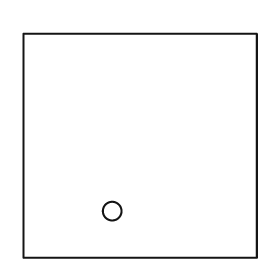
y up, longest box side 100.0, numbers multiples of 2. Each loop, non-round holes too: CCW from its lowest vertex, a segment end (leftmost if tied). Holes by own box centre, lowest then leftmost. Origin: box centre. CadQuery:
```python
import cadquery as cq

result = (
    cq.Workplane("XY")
    .moveTo(-50.0, -48.0)
    .lineTo(50.0, -48.0)
    .lineTo(50.0, 48.0)
    .lineTo(-50.0, 48.0)
    .close()
    .moveTo(-12.0, -28.0)
    .circle(4.0)
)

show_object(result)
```